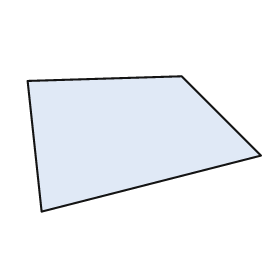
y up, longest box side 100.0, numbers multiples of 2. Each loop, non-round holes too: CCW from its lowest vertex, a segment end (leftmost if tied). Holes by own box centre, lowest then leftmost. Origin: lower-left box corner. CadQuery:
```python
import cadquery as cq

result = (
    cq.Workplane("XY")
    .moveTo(6.0, 0.0)
    .lineTo(100.0, 24.0)
    .lineTo(66.0, 58.0)
    .lineTo(0.0, 56.0)
    .close()
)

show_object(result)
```